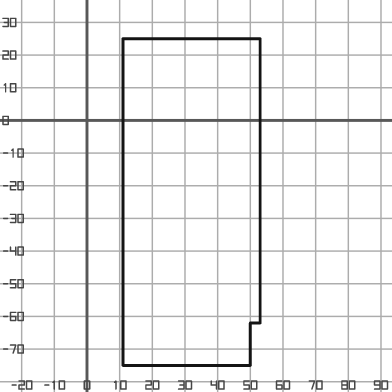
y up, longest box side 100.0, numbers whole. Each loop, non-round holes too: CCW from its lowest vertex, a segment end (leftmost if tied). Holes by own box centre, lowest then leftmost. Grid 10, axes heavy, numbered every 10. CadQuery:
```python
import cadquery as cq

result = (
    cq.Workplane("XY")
    .moveTo(11.0, -75.0)
    .lineTo(50.0, -75.0)
    .lineTo(50.0, -62.0)
    .lineTo(53.0, -62.0)
    .lineTo(53.0, 25.0)
    .lineTo(11.0, 25.0)
    .close()
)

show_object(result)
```